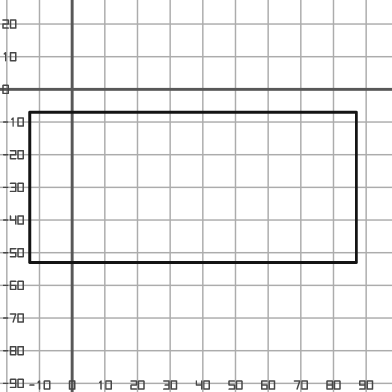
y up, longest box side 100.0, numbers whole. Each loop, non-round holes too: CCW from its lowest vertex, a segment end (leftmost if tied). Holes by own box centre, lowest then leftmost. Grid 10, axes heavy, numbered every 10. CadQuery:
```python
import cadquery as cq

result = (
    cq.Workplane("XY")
    .moveTo(-13.0, -53.0)
    .lineTo(87.0, -53.0)
    .lineTo(87.0, -7.0)
    .lineTo(-13.0, -7.0)
    .close()
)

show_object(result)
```